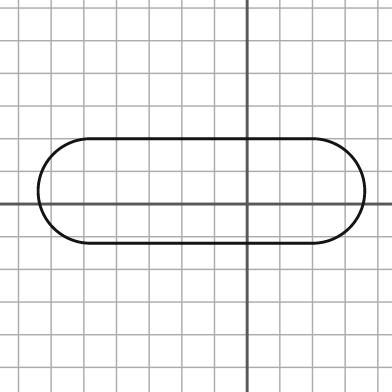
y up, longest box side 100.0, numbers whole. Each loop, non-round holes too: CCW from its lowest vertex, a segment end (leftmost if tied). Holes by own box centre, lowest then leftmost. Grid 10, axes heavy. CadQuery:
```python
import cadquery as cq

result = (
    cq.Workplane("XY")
    .moveTo(-48.0, -12.0)
    .lineTo(20.0, -12.0)
    .threePointArc((36.0, 4.0), (20.0, 20.0))
    .lineTo(-48.0, 20.0)
    .threePointArc((-64.0, 4.0), (-48.0, -12.0))
    .close()
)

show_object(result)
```